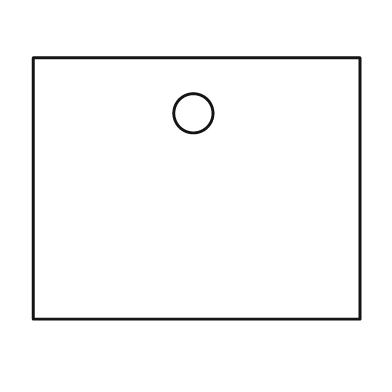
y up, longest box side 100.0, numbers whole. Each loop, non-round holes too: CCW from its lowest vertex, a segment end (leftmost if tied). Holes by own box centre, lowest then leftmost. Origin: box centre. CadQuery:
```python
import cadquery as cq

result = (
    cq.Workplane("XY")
    .moveTo(-50.0, -40.0)
    .lineTo(50.0, -40.0)
    .lineTo(50.0, 40.0)
    .lineTo(-50.0, 40.0)
    .close()
    .moveTo(-1.0, 23.0)
    .circle(6.0)
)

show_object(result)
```